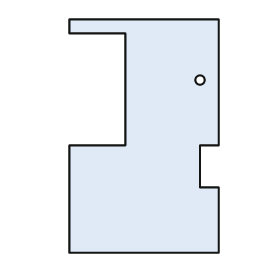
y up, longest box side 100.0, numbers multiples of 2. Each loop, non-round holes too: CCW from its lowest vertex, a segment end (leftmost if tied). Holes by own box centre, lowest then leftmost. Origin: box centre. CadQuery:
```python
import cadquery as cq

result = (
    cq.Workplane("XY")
    .moveTo(-32.0, -50.0)
    .lineTo(32.0, -50.0)
    .lineTo(32.0, -22.0)
    .lineTo(24.0, -22.0)
    .lineTo(24.0, -4.0)
    .lineTo(32.0, -4.0)
    .lineTo(32.0, 50.0)
    .lineTo(-32.0, 50.0)
    .lineTo(-32.0, 44.0)
    .lineTo(-8.0, 44.0)
    .lineTo(-8.0, -4.0)
    .lineTo(-32.0, -4.0)
    .close()
    .moveTo(24.0, 24.0)
    .circle(2.0)
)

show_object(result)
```